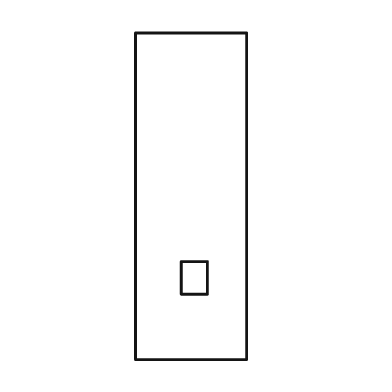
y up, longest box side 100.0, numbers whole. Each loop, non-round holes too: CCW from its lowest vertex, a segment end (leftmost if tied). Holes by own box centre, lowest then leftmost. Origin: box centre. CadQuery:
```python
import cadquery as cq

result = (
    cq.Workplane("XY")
    .moveTo(-17.0, -50.0)
    .lineTo(17.0, -50.0)
    .lineTo(17.0, 50.0)
    .lineTo(-17.0, 50.0)
    .close()
    .moveTo(-3.0, -30.0)
    .lineTo(5.0, -30.0)
    .lineTo(5.0, -20.0)
    .lineTo(-3.0, -20.0)
    .close()
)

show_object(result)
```